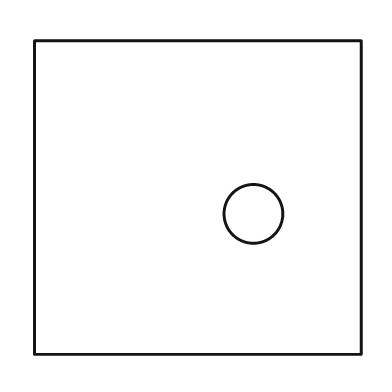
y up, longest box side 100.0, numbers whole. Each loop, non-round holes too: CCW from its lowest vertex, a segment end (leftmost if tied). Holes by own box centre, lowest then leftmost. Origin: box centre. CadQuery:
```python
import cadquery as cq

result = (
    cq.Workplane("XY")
    .moveTo(-50.0, -48.0)
    .lineTo(50.0, -48.0)
    .lineTo(50.0, 48.0)
    .lineTo(-50.0, 48.0)
    .close()
    .moveTo(17.0, -5.0)
    .circle(9.0)
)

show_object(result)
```